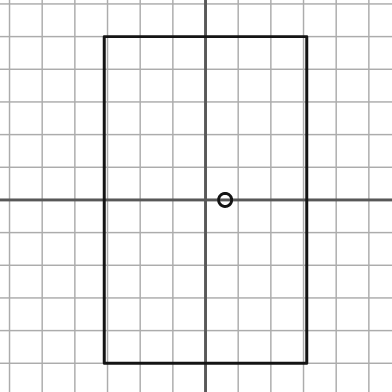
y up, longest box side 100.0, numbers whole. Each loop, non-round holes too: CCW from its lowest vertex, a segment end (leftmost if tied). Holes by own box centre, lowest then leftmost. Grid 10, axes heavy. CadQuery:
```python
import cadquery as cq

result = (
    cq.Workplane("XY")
    .moveTo(-31.0, -50.0)
    .lineTo(31.0, -50.0)
    .lineTo(31.0, 50.0)
    .lineTo(-31.0, 50.0)
    .close()
    .moveTo(6.0, 0.0)
    .circle(2.0)
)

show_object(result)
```